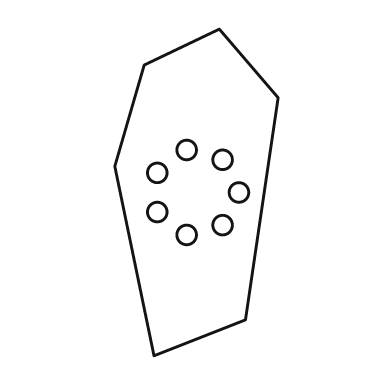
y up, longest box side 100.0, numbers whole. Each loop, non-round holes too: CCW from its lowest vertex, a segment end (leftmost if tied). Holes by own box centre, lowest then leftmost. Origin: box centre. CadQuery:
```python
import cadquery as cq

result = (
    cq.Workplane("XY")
    .moveTo(-13.0, -50.0)
    .lineTo(15.0, -39.0)
    .lineTo(25.0, 29.0)
    .lineTo(7.0, 50.0)
    .lineTo(-16.0, 39.0)
    .lineTo(-25.0, 8.0)
    .close()
    .moveTo(-3.0, -13.0)
    .circle(3.0)
    .moveTo(8.0, -10.0)
    .circle(3.0)
    .moveTo(-12.0, -6.0)
    .circle(3.0)
    .moveTo(13.0, 0.0)
    .circle(3.0)
    .moveTo(-12.0, 6.0)
    .circle(3.0)
    .moveTo(8.0, 10.0)
    .circle(3.0)
    .moveTo(-3.0, 13.0)
    .circle(3.0)
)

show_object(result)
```